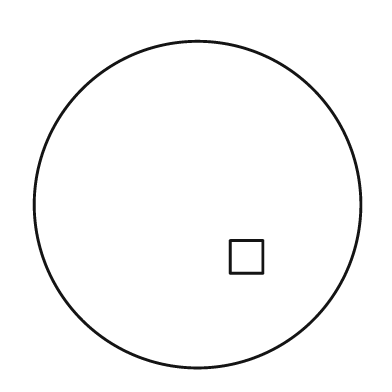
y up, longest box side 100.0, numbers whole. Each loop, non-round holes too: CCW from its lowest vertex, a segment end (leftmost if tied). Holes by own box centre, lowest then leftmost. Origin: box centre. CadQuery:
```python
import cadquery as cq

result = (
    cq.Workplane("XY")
    .moveTo(0.0, 0.0)
    .circle(50.0)
    .moveTo(10.0, -21.0)
    .lineTo(20.0, -21.0)
    .lineTo(20.0, -11.0)
    .lineTo(10.0, -11.0)
    .close()
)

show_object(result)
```